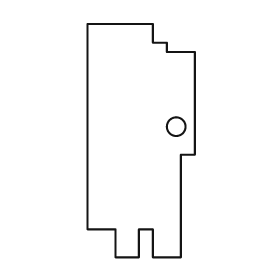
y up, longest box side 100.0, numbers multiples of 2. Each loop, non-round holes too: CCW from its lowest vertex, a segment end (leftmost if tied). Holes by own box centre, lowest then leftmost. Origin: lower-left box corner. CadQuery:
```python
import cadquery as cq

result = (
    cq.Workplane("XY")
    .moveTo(12.0, 0.0)
    .lineTo(22.0, 0.0)
    .lineTo(22.0, 12.0)
    .lineTo(28.0, 12.0)
    .lineTo(28.0, 0.0)
    .lineTo(40.0, 0.0)
    .lineTo(40.0, 44.0)
    .lineTo(46.0, 44.0)
    .lineTo(46.0, 88.0)
    .lineTo(34.0, 88.0)
    .lineTo(34.0, 92.0)
    .lineTo(28.0, 92.0)
    .lineTo(28.0, 100.0)
    .lineTo(0.0, 100.0)
    .lineTo(0.0, 12.0)
    .lineTo(12.0, 12.0)
    .close()
    .moveTo(38.0, 56.0)
    .circle(4.0)
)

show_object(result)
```